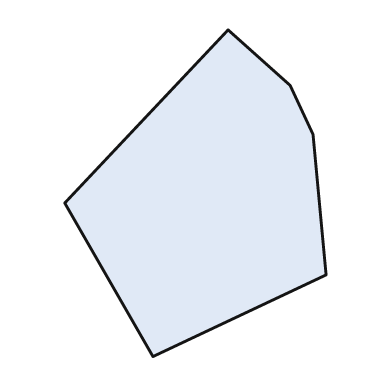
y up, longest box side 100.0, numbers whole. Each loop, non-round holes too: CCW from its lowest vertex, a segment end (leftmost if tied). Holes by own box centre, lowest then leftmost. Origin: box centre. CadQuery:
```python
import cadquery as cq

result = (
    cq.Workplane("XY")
    .moveTo(-13.0, -50.0)
    .lineTo(40.0, -25.0)
    .lineTo(36.0, 18.0)
    .lineTo(29.0, 33.0)
    .lineTo(10.0, 50.0)
    .lineTo(-40.0, -3.0)
    .close()
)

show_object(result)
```